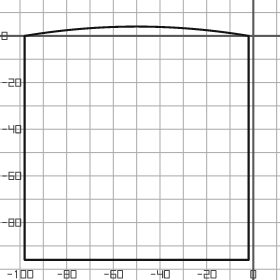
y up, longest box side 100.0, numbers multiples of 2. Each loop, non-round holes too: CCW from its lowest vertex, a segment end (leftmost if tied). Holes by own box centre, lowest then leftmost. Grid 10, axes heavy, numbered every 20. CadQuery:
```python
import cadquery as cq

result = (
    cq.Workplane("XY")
    .moveTo(-98.0, -96.0)
    .lineTo(-2.0, -96.0)
    .lineTo(-2.0, 0.0)
    .threePointArc((-50.0, 4.0), (-98.0, 0.0))
    .close()
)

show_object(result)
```